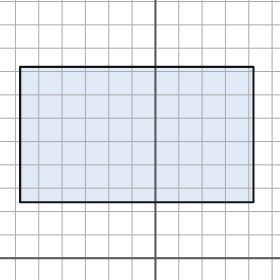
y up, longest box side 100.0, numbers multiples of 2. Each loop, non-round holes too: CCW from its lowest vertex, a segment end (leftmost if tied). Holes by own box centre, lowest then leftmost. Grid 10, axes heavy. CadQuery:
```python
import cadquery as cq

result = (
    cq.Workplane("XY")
    .moveTo(-58.0, 24.0)
    .lineTo(42.0, 24.0)
    .lineTo(42.0, 82.0)
    .lineTo(-58.0, 82.0)
    .close()
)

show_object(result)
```